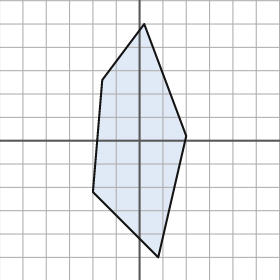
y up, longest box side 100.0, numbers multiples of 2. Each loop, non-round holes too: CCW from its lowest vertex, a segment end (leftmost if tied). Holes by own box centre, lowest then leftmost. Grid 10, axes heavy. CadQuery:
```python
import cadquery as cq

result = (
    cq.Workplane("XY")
    .moveTo(8.0, -50.0)
    .lineTo(20.0, 2.0)
    .lineTo(2.0, 50.0)
    .lineTo(-16.0, 26.0)
    .lineTo(-20.0, -22.0)
    .close()
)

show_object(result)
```